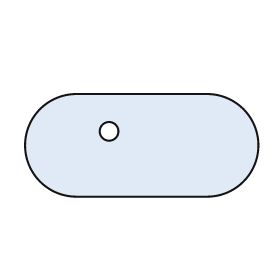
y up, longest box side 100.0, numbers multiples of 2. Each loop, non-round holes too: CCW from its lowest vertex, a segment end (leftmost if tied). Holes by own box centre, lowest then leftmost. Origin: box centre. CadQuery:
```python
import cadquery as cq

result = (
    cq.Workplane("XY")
    .moveTo(-28.0, -22.0)
    .lineTo(28.0, -22.0)
    .threePointArc((50.0, 0.0), (28.0, 22.0))
    .lineTo(-28.0, 22.0)
    .threePointArc((-50.0, 0.0), (-28.0, -22.0))
    .close()
    .moveTo(-14.0, 6.0)
    .circle(4.0)
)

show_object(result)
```